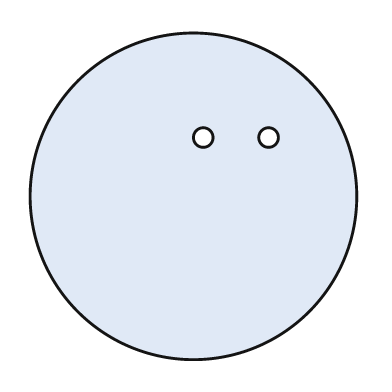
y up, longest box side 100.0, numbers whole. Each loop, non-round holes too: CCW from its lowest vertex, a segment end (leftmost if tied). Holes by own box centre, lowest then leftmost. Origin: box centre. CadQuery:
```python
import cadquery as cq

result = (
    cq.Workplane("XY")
    .moveTo(0.0, 0.0)
    .circle(50.0)
    .moveTo(3.0, 18.0)
    .circle(3.0)
    .moveTo(23.0, 18.0)
    .circle(3.0)
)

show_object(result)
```